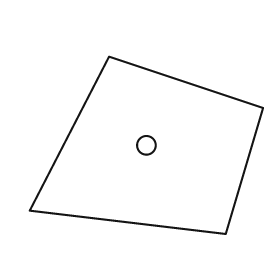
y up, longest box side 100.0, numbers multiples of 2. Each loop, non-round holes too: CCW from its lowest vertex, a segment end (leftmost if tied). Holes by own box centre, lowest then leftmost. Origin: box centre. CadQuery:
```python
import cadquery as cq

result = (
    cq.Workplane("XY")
    .moveTo(34.0, -38.0)
    .lineTo(50.0, 16.0)
    .lineTo(-16.0, 38.0)
    .lineTo(-50.0, -28.0)
    .close()
    .moveTo(0.0, 0.0)
    .circle(4.0)
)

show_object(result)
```